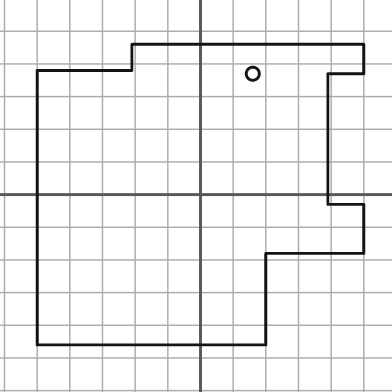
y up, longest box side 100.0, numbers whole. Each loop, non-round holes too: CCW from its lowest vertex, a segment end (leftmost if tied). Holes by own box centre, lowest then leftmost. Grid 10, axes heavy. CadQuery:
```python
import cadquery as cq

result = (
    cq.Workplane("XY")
    .moveTo(-50.0, -46.0)
    .lineTo(20.0, -46.0)
    .lineTo(20.0, -18.0)
    .lineTo(50.0, -18.0)
    .lineTo(50.0, -3.0)
    .lineTo(39.0, -3.0)
    .lineTo(39.0, 37.0)
    .lineTo(50.0, 37.0)
    .lineTo(50.0, 46.0)
    .lineTo(-21.0, 46.0)
    .lineTo(-21.0, 38.0)
    .lineTo(-50.0, 38.0)
    .close()
    .moveTo(16.0, 37.0)
    .circle(2.0)
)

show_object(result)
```